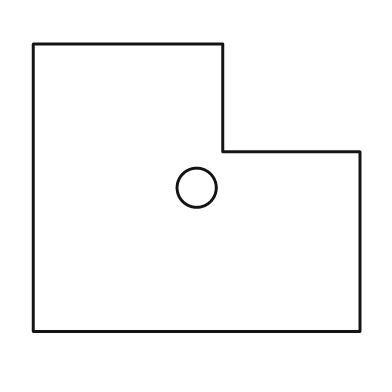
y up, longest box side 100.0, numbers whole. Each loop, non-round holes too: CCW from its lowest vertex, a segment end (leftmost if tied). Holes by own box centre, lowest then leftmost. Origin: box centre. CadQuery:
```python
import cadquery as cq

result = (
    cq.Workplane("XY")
    .moveTo(-50.0, -44.0)
    .lineTo(50.0, -44.0)
    .lineTo(50.0, 11.0)
    .lineTo(8.0, 11.0)
    .lineTo(8.0, 44.0)
    .lineTo(-50.0, 44.0)
    .close()
    .moveTo(0.0, 0.0)
    .circle(6.0)
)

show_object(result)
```